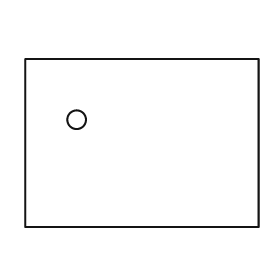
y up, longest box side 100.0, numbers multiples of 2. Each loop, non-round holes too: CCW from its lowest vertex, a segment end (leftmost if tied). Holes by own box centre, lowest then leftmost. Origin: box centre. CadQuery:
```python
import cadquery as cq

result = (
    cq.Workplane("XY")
    .moveTo(-50.0, -36.0)
    .lineTo(50.0, -36.0)
    .lineTo(50.0, 36.0)
    .lineTo(-50.0, 36.0)
    .close()
    .moveTo(-28.0, 10.0)
    .circle(4.0)
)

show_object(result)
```